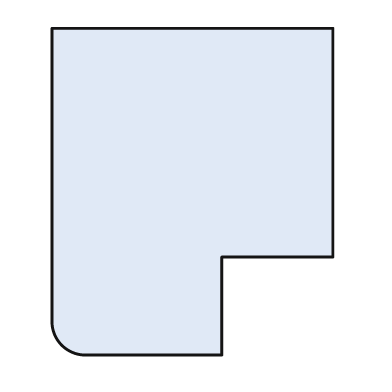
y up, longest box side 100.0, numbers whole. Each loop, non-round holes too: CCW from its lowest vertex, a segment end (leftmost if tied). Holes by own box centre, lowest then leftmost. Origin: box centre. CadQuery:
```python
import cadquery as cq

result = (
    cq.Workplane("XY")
    .moveTo(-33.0, -50.0)
    .lineTo(9.0, -50.0)
    .lineTo(9.0, -20.0)
    .lineTo(43.0, -20.0)
    .lineTo(43.0, 50.0)
    .lineTo(-43.0, 50.0)
    .lineTo(-43.0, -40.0)
    .threePointArc((-40.0, -47.0), (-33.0, -50.0))
    .close()
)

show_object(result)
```